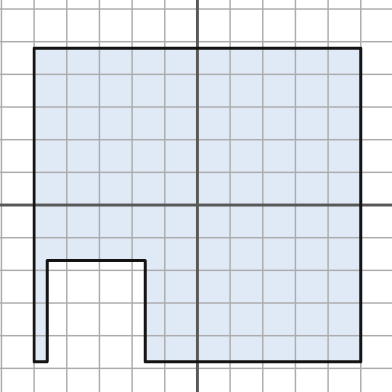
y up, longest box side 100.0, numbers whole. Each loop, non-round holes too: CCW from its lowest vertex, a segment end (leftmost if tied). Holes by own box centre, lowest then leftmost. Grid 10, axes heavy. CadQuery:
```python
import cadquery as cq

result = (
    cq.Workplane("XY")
    .moveTo(-50.0, -48.0)
    .lineTo(-46.0, -48.0)
    .lineTo(-46.0, -17.0)
    .lineTo(-16.0, -17.0)
    .lineTo(-16.0, -48.0)
    .lineTo(50.0, -48.0)
    .lineTo(50.0, 48.0)
    .lineTo(-50.0, 48.0)
    .close()
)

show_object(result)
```